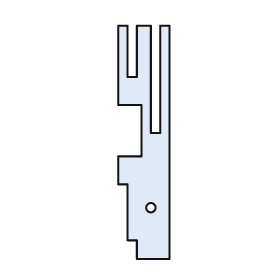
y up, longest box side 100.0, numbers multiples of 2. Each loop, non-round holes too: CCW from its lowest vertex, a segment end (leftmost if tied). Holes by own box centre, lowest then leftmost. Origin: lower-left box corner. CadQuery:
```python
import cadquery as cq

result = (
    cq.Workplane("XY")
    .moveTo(8.0, 0.0)
    .lineTo(22.0, 0.0)
    .lineTo(22.0, 100.0)
    .lineTo(18.0, 100.0)
    .lineTo(18.0, 54.0)
    .lineTo(14.0, 54.0)
    .lineTo(14.0, 100.0)
    .lineTo(8.0, 100.0)
    .lineTo(8.0, 78.0)
    .lineTo(4.0, 78.0)
    .lineTo(4.0, 100.0)
    .lineTo(0.0, 100.0)
    .lineTo(0.0, 66.0)
    .lineTo(10.0, 66.0)
    .lineTo(10.0, 44.0)
    .lineTo(0.0, 44.0)
    .lineTo(0.0, 32.0)
    .lineTo(4.0, 32.0)
    .lineTo(4.0, 8.0)
    .lineTo(8.0, 8.0)
    .close()
    .moveTo(14.0, 22.0)
    .circle(2.0)
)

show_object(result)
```